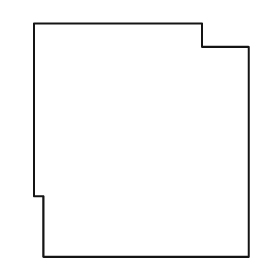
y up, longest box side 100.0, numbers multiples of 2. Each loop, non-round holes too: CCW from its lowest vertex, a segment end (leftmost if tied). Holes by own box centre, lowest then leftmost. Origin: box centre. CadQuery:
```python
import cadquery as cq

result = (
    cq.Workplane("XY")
    .moveTo(-42.0, -50.0)
    .lineTo(46.0, -50.0)
    .lineTo(46.0, 40.0)
    .lineTo(26.0, 40.0)
    .lineTo(26.0, 50.0)
    .lineTo(-46.0, 50.0)
    .lineTo(-46.0, -24.0)
    .lineTo(-42.0, -24.0)
    .close()
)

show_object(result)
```